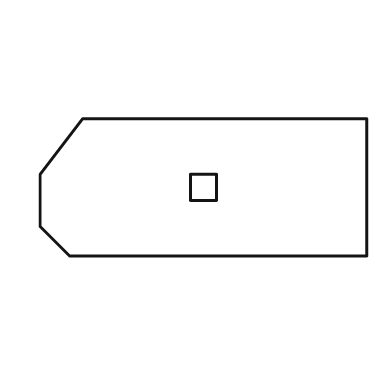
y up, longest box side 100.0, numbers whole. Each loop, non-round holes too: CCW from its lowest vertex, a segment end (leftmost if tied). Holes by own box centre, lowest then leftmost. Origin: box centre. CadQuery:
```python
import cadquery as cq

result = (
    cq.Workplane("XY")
    .moveTo(-41.0, -21.0)
    .lineTo(50.0, -21.0)
    .lineTo(50.0, 21.0)
    .lineTo(-37.0, 21.0)
    .lineTo(-50.0, 4.0)
    .lineTo(-50.0, -12.0)
    .close()
    .moveTo(-4.0, -4.0)
    .lineTo(4.0, -4.0)
    .lineTo(4.0, 4.0)
    .lineTo(-4.0, 4.0)
    .close()
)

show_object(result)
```